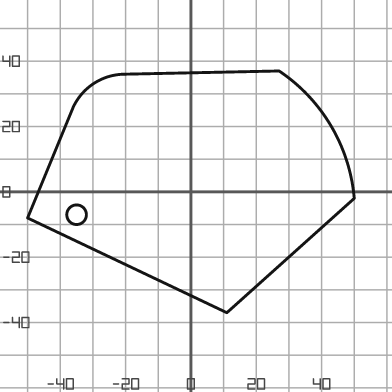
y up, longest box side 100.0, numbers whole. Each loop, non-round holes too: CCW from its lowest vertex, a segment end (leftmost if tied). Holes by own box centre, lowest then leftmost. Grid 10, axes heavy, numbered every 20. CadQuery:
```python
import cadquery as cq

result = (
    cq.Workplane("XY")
    .moveTo(11.0, -37.0)
    .lineTo(50.0, -2.0)
    .threePointArc((43.0, 20.0), (27.0, 37.0))
    .lineTo(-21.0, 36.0)
    .threePointArc((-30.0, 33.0), (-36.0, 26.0))
    .lineTo(-50.0, -8.0)
    .close()
    .moveTo(-35.0, -7.0)
    .circle(3.0)
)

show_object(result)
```